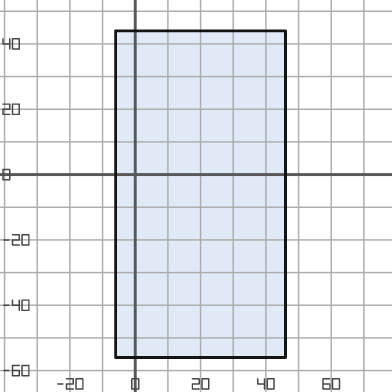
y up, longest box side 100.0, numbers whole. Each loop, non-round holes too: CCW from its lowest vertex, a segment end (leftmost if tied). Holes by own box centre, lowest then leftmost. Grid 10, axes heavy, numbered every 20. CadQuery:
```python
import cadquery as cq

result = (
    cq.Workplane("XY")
    .moveTo(-6.0, -56.0)
    .lineTo(46.0, -56.0)
    .lineTo(46.0, 44.0)
    .lineTo(-6.0, 44.0)
    .close()
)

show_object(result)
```